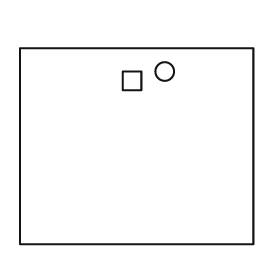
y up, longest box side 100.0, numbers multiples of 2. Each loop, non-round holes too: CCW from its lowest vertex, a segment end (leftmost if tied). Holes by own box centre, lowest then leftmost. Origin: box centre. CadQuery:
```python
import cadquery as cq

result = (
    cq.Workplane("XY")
    .moveTo(-50.0, -42.0)
    .lineTo(50.0, -42.0)
    .lineTo(50.0, 42.0)
    .lineTo(-50.0, 42.0)
    .close()
    .moveTo(-6.0, 24.0)
    .lineTo(2.0, 24.0)
    .lineTo(2.0, 32.0)
    .lineTo(-6.0, 32.0)
    .close()
    .moveTo(12.0, 32.0)
    .circle(4.0)
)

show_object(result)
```